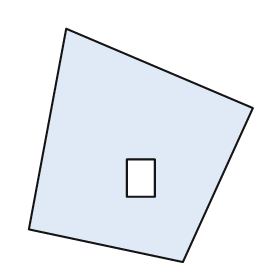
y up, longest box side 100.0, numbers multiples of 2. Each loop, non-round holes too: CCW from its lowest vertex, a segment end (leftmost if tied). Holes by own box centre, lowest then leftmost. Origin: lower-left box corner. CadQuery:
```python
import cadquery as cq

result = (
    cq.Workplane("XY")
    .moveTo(66.0, 0.0)
    .lineTo(96.0, 66.0)
    .lineTo(16.0, 100.0)
    .lineTo(0.0, 14.0)
    .close()
    .moveTo(42.0, 28.0)
    .lineTo(54.0, 28.0)
    .lineTo(54.0, 44.0)
    .lineTo(42.0, 44.0)
    .close()
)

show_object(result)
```